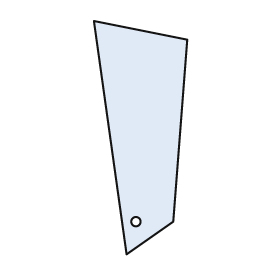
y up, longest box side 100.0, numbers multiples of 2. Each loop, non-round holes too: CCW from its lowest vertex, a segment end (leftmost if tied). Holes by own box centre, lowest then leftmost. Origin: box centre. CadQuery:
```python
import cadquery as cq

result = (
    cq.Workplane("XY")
    .moveTo(-6.0, -50.0)
    .lineTo(14.0, -36.0)
    .lineTo(20.0, 42.0)
    .lineTo(-20.0, 50.0)
    .close()
    .moveTo(-2.0, -36.0)
    .circle(2.0)
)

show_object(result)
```